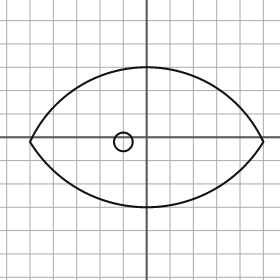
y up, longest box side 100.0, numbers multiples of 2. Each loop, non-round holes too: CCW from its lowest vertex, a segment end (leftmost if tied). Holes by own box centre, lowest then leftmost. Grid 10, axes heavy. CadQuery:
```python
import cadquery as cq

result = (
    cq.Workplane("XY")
    .moveTo(-50.0, -2.0)
    .threePointArc((0.0, -30.0), (50.0, -2.0))
    .threePointArc((0.0, 30.0), (-50.0, -2.0))
    .close()
    .moveTo(-10.0, -2.0)
    .circle(4.0)
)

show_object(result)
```